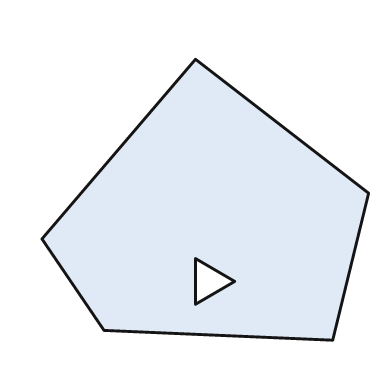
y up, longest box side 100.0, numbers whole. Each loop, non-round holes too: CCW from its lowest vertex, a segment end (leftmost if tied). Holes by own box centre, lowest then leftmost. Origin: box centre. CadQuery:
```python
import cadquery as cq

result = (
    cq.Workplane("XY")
    .moveTo(39.0, -43.0)
    .lineTo(50.0, 2.0)
    .lineTo(-3.0, 43.0)
    .lineTo(-50.0, -12.0)
    .lineTo(-31.0, -40.0)
    .close()
    .moveTo(-3.0, -32.0)
    .lineTo(9.0, -25.0)
    .lineTo(-3.0, -18.0)
    .close()
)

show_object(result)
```